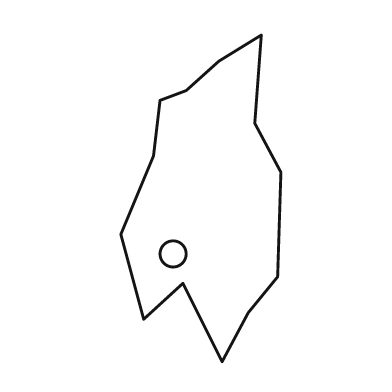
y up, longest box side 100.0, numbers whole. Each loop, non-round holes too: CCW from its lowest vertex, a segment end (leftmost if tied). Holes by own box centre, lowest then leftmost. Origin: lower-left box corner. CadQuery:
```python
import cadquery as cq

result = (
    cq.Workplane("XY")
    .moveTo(31.0, 0.0)
    .lineTo(39.0, 15.0)
    .lineTo(48.0, 26.0)
    .lineTo(49.0, 58.0)
    .lineTo(41.0, 73.0)
    .lineTo(43.0, 100.0)
    .lineTo(30.0, 92.0)
    .lineTo(20.0, 83.0)
    .lineTo(12.0, 80.0)
    .lineTo(10.0, 63.0)
    .lineTo(0.0, 39.0)
    .lineTo(7.0, 13.0)
    .lineTo(19.0, 24.0)
    .close()
    .moveTo(16.0, 33.0)
    .circle(4.0)
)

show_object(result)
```